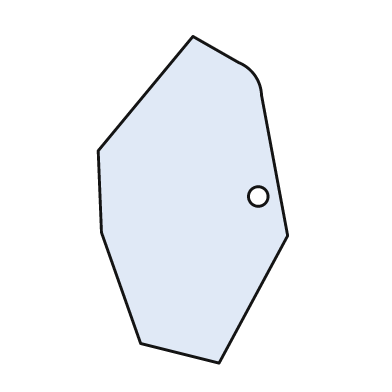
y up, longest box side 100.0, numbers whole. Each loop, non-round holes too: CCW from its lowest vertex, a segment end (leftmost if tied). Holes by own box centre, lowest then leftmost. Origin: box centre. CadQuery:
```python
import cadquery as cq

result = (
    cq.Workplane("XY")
    .moveTo(8.0, -50.0)
    .lineTo(29.0, -11.0)
    .lineTo(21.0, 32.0)
    .threePointArc((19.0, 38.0), (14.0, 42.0))
    .lineTo(0.0, 50.0)
    .lineTo(-29.0, 15.0)
    .lineTo(-28.0, -10.0)
    .lineTo(-16.0, -44.0)
    .close()
    .moveTo(20.0, 1.0)
    .circle(3.0)
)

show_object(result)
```